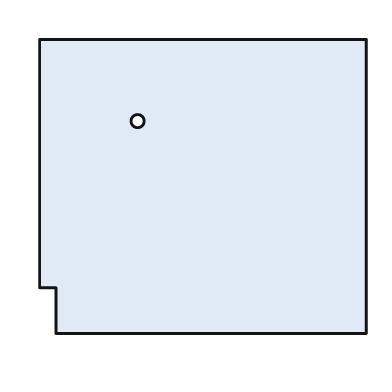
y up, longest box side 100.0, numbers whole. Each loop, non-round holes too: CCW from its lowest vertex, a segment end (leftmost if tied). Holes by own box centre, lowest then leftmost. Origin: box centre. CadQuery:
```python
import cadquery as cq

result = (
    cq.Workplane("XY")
    .moveTo(-45.0, -45.0)
    .lineTo(50.0, -45.0)
    .lineTo(50.0, 45.0)
    .lineTo(-50.0, 45.0)
    .lineTo(-50.0, -31.0)
    .lineTo(-45.0, -31.0)
    .close()
    .moveTo(-20.0, 20.0)
    .circle(2.0)
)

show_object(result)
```